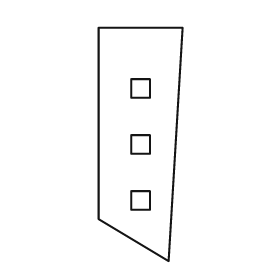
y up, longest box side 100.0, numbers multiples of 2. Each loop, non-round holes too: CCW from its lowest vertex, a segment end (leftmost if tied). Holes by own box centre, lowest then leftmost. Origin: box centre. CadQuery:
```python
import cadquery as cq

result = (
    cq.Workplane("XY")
    .moveTo(12.0, -50.0)
    .lineTo(18.0, 50.0)
    .lineTo(-18.0, 50.0)
    .lineTo(-18.0, -32.0)
    .close()
    .moveTo(-4.0, -28.0)
    .lineTo(4.0, -28.0)
    .lineTo(4.0, -20.0)
    .lineTo(-4.0, -20.0)
    .close()
    .moveTo(-4.0, -4.0)
    .lineTo(4.0, -4.0)
    .lineTo(4.0, 4.0)
    .lineTo(-4.0, 4.0)
    .close()
    .moveTo(-4.0, 20.0)
    .lineTo(4.0, 20.0)
    .lineTo(4.0, 28.0)
    .lineTo(-4.0, 28.0)
    .close()
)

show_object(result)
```